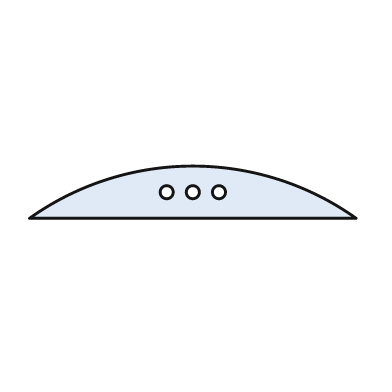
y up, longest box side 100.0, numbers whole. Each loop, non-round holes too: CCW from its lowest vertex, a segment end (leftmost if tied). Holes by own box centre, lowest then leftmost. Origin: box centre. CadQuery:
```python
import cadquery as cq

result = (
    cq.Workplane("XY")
    .moveTo(-50.0, -8.0)
    .lineTo(50.0, -8.0)
    .threePointArc((0.0, 8.0), (-50.0, -8.0))
    .close()
    .moveTo(-8.0, 0.0)
    .circle(2.0)
    .moveTo(0.0, 0.0)
    .circle(2.0)
    .moveTo(8.0, 0.0)
    .circle(2.0)
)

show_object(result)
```